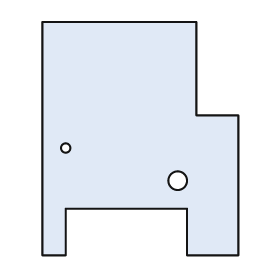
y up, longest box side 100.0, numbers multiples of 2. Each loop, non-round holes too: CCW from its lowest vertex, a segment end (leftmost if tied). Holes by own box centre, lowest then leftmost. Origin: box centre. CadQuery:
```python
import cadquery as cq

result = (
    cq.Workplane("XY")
    .moveTo(-42.0, -50.0)
    .lineTo(-32.0, -50.0)
    .lineTo(-32.0, -30.0)
    .lineTo(20.0, -30.0)
    .lineTo(20.0, -50.0)
    .lineTo(42.0, -50.0)
    .lineTo(42.0, 10.0)
    .lineTo(24.0, 10.0)
    .lineTo(24.0, 50.0)
    .lineTo(-42.0, 50.0)
    .close()
    .moveTo(16.0, -18.0)
    .circle(4.0)
    .moveTo(-32.0, -4.0)
    .circle(2.0)
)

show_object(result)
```